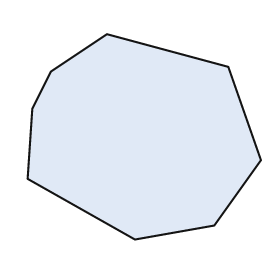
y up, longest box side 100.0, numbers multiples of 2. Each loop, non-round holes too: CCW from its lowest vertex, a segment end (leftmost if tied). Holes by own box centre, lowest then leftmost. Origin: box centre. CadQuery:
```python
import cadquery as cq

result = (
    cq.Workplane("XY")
    .moveTo(-4.0, -44.0)
    .lineTo(30.0, -38.0)
    .lineTo(50.0, -10.0)
    .lineTo(36.0, 30.0)
    .lineTo(-16.0, 44.0)
    .lineTo(-40.0, 28.0)
    .lineTo(-48.0, 12.0)
    .lineTo(-50.0, -18.0)
    .close()
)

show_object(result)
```